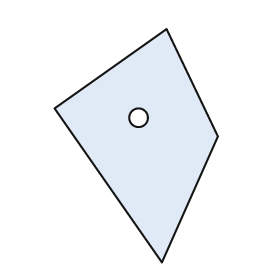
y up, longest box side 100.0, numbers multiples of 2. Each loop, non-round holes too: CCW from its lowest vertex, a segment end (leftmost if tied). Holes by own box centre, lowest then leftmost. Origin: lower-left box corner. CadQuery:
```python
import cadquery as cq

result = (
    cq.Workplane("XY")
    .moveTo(46.0, 0.0)
    .lineTo(70.0, 54.0)
    .lineTo(48.0, 100.0)
    .lineTo(0.0, 66.0)
    .close()
    .moveTo(36.0, 62.0)
    .circle(4.0)
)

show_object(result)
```